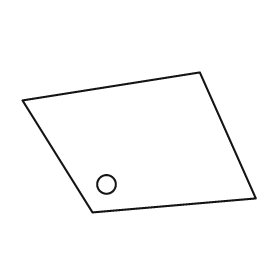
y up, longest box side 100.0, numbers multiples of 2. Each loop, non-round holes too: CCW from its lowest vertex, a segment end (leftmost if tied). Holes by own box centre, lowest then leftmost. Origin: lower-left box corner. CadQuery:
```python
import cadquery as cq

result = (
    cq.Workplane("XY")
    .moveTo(30.0, 0.0)
    .lineTo(100.0, 6.0)
    .lineTo(76.0, 60.0)
    .lineTo(0.0, 48.0)
    .close()
    .moveTo(36.0, 12.0)
    .circle(4.0)
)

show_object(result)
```